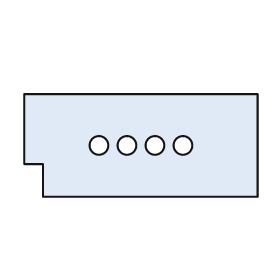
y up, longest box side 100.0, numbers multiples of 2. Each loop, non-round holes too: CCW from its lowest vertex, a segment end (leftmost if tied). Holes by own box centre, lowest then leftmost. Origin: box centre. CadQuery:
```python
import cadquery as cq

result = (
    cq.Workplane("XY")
    .moveTo(-42.0, -22.0)
    .lineTo(50.0, -22.0)
    .lineTo(50.0, 22.0)
    .lineTo(-50.0, 22.0)
    .lineTo(-50.0, -8.0)
    .lineTo(-42.0, -8.0)
    .close()
    .moveTo(-18.0, 0.0)
    .circle(4.0)
    .moveTo(-6.0, 0.0)
    .circle(4.0)
    .moveTo(6.0, 0.0)
    .circle(4.0)
    .moveTo(18.0, 0.0)
    .circle(4.0)
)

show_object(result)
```